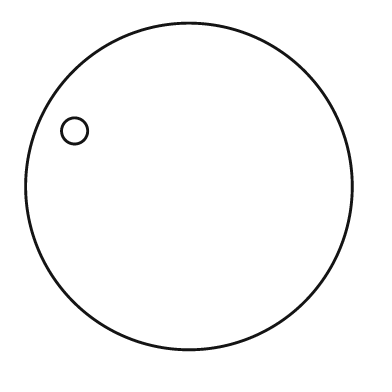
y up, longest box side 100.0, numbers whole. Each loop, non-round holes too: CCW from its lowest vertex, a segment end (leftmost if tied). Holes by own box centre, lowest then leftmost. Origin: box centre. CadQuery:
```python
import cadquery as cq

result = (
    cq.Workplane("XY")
    .moveTo(0.0, 0.0)
    .circle(50.0)
    .moveTo(-35.0, 17.0)
    .circle(4.0)
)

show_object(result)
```